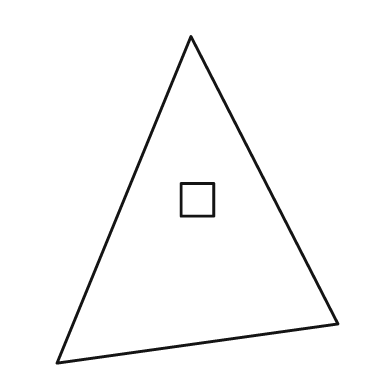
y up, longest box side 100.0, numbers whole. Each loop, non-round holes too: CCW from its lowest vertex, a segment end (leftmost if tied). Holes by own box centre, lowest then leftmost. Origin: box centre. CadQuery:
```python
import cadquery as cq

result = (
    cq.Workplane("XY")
    .moveTo(-43.0, -50.0)
    .lineTo(43.0, -38.0)
    .lineTo(-2.0, 50.0)
    .close()
    .moveTo(-5.0, -5.0)
    .lineTo(5.0, -5.0)
    .lineTo(5.0, 5.0)
    .lineTo(-5.0, 5.0)
    .close()
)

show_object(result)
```